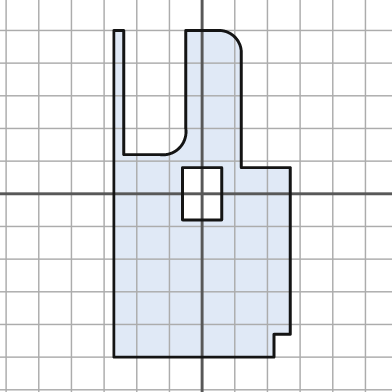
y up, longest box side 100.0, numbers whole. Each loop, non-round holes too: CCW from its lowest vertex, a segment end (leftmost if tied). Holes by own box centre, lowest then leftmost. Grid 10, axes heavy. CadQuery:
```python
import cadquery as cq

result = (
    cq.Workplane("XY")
    .moveTo(-27.0, -50.0)
    .lineTo(22.0, -50.0)
    .lineTo(22.0, -43.0)
    .lineTo(27.0, -43.0)
    .lineTo(27.0, 8.0)
    .lineTo(12.0, 8.0)
    .lineTo(12.0, 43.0)
    .threePointArc((10.0, 48.0), (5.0, 50.0))
    .lineTo(-5.0, 50.0)
    .lineTo(-5.0, 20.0)
    .threePointArc((-7.0, 14.0), (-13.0, 12.0))
    .lineTo(-24.0, 12.0)
    .lineTo(-24.0, 50.0)
    .lineTo(-27.0, 50.0)
    .close()
    .moveTo(-6.0, -8.0)
    .lineTo(6.0, -8.0)
    .lineTo(6.0, 8.0)
    .lineTo(-6.0, 8.0)
    .close()
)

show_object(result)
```